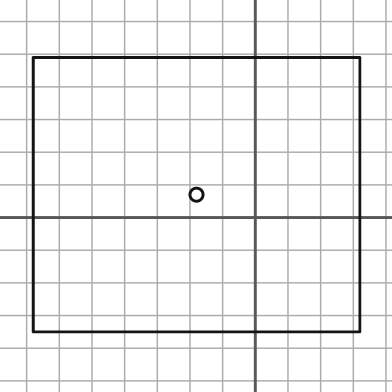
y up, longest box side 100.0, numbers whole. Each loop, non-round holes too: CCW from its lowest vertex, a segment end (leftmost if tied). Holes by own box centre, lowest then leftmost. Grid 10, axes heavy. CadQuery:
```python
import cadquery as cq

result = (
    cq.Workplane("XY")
    .moveTo(-68.0, -35.0)
    .lineTo(32.0, -35.0)
    .lineTo(32.0, 49.0)
    .lineTo(-68.0, 49.0)
    .close()
    .moveTo(-18.0, 7.0)
    .circle(2.0)
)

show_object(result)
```